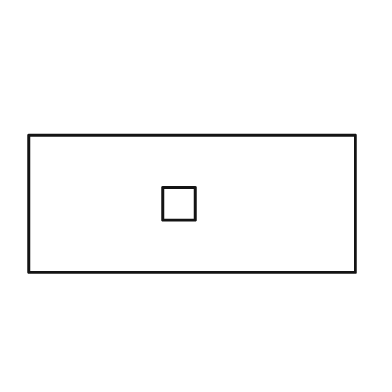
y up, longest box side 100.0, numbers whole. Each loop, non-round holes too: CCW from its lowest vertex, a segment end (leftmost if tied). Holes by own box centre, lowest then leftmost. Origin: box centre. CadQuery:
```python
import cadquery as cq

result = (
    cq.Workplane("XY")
    .moveTo(-50.0, -21.0)
    .lineTo(50.0, -21.0)
    .lineTo(50.0, 21.0)
    .lineTo(-50.0, 21.0)
    .close()
    .moveTo(-9.0, -5.0)
    .lineTo(1.0, -5.0)
    .lineTo(1.0, 5.0)
    .lineTo(-9.0, 5.0)
    .close()
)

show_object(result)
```